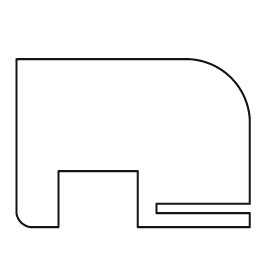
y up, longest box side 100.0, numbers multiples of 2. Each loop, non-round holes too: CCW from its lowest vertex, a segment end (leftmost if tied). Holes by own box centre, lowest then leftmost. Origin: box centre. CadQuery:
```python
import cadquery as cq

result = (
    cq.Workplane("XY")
    .moveTo(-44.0, -36.0)
    .lineTo(-32.0, -36.0)
    .lineTo(-32.0, -12.0)
    .lineTo(2.0, -12.0)
    .lineTo(2.0, -36.0)
    .lineTo(50.0, -36.0)
    .lineTo(50.0, -30.0)
    .lineTo(10.0, -30.0)
    .lineTo(10.0, -26.0)
    .lineTo(50.0, -26.0)
    .lineTo(50.0, 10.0)
    .threePointArc((42.0, 28.0), (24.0, 36.0))
    .lineTo(-50.0, 36.0)
    .lineTo(-50.0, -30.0)
    .threePointArc((-48.0, -34.0), (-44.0, -36.0))
    .close()
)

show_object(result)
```